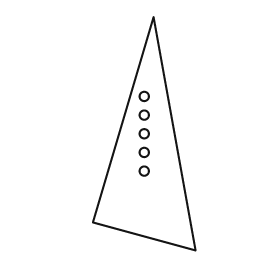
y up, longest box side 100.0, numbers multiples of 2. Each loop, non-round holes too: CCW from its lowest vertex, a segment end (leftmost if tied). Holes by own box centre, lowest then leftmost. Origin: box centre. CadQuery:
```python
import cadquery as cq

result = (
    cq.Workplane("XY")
    .moveTo(22.0, -50.0)
    .lineTo(4.0, 50.0)
    .lineTo(-22.0, -38.0)
    .close()
    .moveTo(0.0, -16.0)
    .circle(2.0)
    .moveTo(0.0, -8.0)
    .circle(2.0)
    .moveTo(0.0, 0.0)
    .circle(2.0)
    .moveTo(0.0, 8.0)
    .circle(2.0)
    .moveTo(0.0, 16.0)
    .circle(2.0)
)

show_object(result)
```